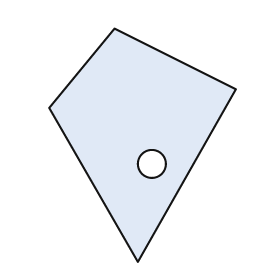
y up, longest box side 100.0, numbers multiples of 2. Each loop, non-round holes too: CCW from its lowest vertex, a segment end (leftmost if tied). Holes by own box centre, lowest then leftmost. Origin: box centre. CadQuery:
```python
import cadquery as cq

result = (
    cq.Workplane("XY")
    .moveTo(-2.0, -50.0)
    .lineTo(40.0, 24.0)
    .lineTo(-12.0, 50.0)
    .lineTo(-40.0, 16.0)
    .close()
    .moveTo(4.0, -8.0)
    .circle(6.0)
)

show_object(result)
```